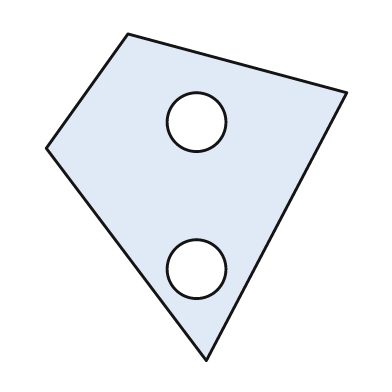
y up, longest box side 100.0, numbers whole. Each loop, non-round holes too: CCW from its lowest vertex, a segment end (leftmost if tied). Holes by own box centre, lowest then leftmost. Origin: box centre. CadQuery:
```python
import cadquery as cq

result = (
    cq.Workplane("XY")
    .moveTo(3.0, -50.0)
    .lineTo(46.0, 32.0)
    .lineTo(-21.0, 50.0)
    .lineTo(-46.0, 15.0)
    .close()
    .moveTo(0.0, -22.0)
    .circle(9.0)
    .moveTo(0.0, 23.0)
    .circle(9.0)
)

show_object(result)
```